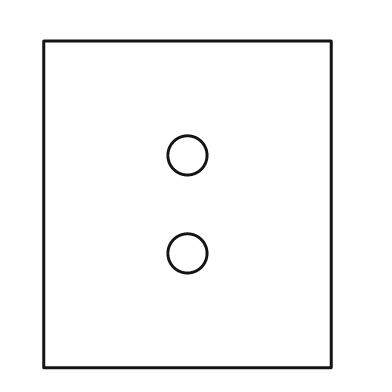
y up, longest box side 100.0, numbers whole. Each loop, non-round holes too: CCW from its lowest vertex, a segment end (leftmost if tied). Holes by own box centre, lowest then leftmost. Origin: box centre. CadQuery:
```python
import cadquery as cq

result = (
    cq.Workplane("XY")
    .moveTo(-44.0, -50.0)
    .lineTo(44.0, -50.0)
    .lineTo(44.0, 50.0)
    .lineTo(-44.0, 50.0)
    .close()
    .moveTo(0.0, -15.0)
    .circle(6.0)
    .moveTo(0.0, 15.0)
    .circle(6.0)
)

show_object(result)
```